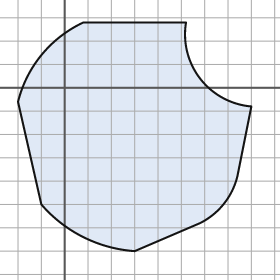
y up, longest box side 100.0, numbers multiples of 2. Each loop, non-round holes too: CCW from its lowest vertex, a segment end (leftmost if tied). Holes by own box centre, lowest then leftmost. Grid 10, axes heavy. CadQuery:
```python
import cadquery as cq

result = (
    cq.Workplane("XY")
    .moveTo(30.0, -70.0)
    .lineTo(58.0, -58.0)
    .threePointArc((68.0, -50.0), (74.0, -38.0))
    .lineTo(80.0, -8.0)
    .threePointArc((58.0, 4.0), (52.0, 28.0))
    .lineTo(8.0, 28.0)
    .threePointArc((-10.0, 14.0), (-20.0, -6.0))
    .lineTo(-10.0, -50.0)
    .threePointArc((8.0, -64.0), (30.0, -70.0))
    .close()
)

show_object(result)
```